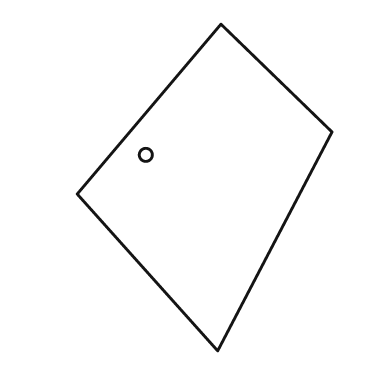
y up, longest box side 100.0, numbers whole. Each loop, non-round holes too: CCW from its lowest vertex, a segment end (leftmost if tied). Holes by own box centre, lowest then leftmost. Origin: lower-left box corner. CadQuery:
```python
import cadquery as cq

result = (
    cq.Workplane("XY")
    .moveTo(43.0, 0.0)
    .lineTo(78.0, 67.0)
    .lineTo(44.0, 100.0)
    .lineTo(0.0, 48.0)
    .close()
    .moveTo(21.0, 60.0)
    .circle(2.0)
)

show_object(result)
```